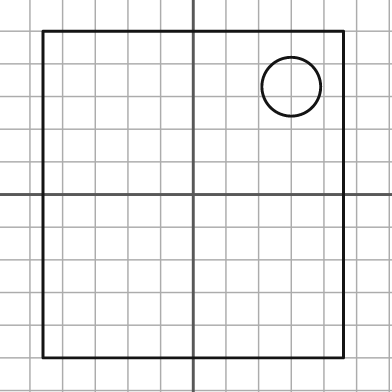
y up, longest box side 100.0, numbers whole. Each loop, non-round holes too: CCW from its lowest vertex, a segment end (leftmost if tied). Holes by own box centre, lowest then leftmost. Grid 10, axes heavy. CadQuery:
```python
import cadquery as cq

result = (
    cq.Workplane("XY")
    .moveTo(-46.0, -50.0)
    .lineTo(46.0, -50.0)
    .lineTo(46.0, 50.0)
    .lineTo(-46.0, 50.0)
    .close()
    .moveTo(30.0, 33.0)
    .circle(9.0)
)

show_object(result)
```